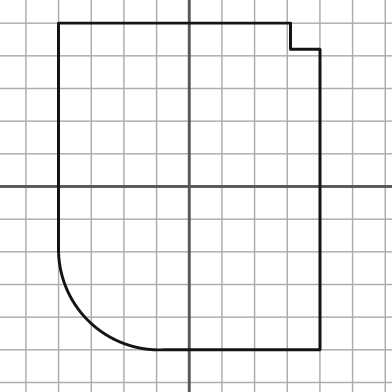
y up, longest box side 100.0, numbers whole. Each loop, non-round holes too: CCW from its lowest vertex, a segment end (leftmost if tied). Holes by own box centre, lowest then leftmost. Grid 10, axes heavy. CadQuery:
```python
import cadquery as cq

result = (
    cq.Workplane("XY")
    .moveTo(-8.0, -50.0)
    .lineTo(40.0, -50.0)
    .lineTo(40.0, 42.0)
    .lineTo(31.0, 42.0)
    .lineTo(31.0, 50.0)
    .lineTo(-40.0, 50.0)
    .lineTo(-40.0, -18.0)
    .threePointArc((-31.0, -41.0), (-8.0, -50.0))
    .close()
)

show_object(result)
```